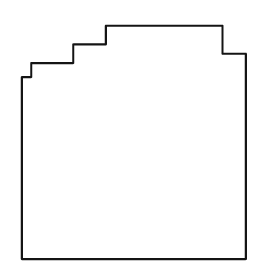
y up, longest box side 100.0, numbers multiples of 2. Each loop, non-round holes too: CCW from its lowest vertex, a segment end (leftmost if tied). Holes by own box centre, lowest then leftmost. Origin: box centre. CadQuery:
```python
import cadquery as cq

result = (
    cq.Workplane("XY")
    .moveTo(-48.0, -50.0)
    .lineTo(48.0, -50.0)
    .lineTo(48.0, 38.0)
    .lineTo(38.0, 38.0)
    .lineTo(38.0, 50.0)
    .lineTo(-12.0, 50.0)
    .lineTo(-12.0, 42.0)
    .lineTo(-26.0, 42.0)
    .lineTo(-26.0, 34.0)
    .lineTo(-44.0, 34.0)
    .lineTo(-44.0, 28.0)
    .lineTo(-48.0, 28.0)
    .close()
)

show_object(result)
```